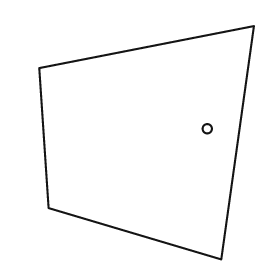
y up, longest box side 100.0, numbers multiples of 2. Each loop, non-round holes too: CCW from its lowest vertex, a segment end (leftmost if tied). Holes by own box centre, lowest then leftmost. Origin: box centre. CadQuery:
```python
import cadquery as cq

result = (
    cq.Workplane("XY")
    .moveTo(32.0, -50.0)
    .lineTo(46.0, 50.0)
    .lineTo(-46.0, 32.0)
    .lineTo(-42.0, -28.0)
    .close()
    .moveTo(26.0, 6.0)
    .circle(2.0)
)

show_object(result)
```